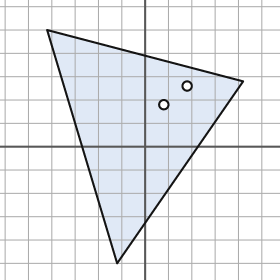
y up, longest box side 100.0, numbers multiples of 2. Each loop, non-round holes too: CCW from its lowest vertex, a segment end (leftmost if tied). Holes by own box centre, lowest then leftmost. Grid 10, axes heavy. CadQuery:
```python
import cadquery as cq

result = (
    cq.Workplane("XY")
    .moveTo(-12.0, -50.0)
    .lineTo(42.0, 28.0)
    .lineTo(-42.0, 50.0)
    .close()
    .moveTo(8.0, 18.0)
    .circle(2.0)
    .moveTo(18.0, 26.0)
    .circle(2.0)
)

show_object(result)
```